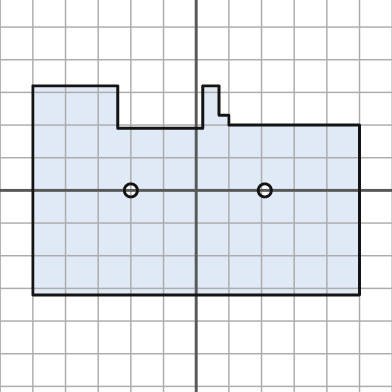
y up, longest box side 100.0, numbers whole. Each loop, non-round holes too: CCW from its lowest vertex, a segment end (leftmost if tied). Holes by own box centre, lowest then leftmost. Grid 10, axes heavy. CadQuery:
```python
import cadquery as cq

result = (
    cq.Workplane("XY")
    .moveTo(-50.0, -32.0)
    .lineTo(50.0, -32.0)
    .lineTo(50.0, 20.0)
    .lineTo(10.0, 20.0)
    .lineTo(10.0, 23.0)
    .lineTo(7.0, 23.0)
    .lineTo(7.0, 32.0)
    .lineTo(2.0, 32.0)
    .lineTo(2.0, 19.0)
    .lineTo(-24.0, 19.0)
    .lineTo(-24.0, 32.0)
    .lineTo(-50.0, 32.0)
    .close()
    .moveTo(-20.0, 0.0)
    .circle(2.0)
    .moveTo(21.0, 0.0)
    .circle(2.0)
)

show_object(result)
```